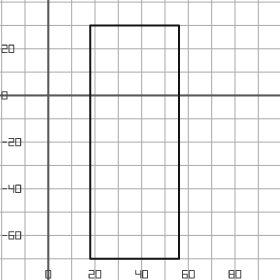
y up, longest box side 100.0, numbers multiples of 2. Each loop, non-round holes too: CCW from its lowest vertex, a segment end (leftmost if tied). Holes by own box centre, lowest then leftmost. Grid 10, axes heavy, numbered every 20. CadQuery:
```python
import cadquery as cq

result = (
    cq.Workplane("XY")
    .moveTo(18.0, -70.0)
    .lineTo(56.0, -70.0)
    .lineTo(56.0, 30.0)
    .lineTo(18.0, 30.0)
    .close()
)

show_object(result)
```